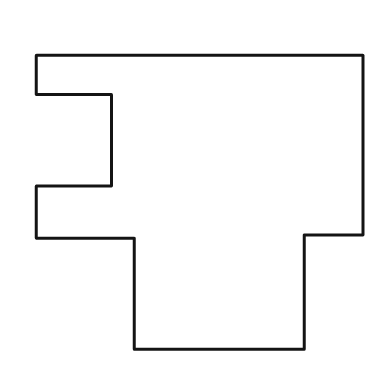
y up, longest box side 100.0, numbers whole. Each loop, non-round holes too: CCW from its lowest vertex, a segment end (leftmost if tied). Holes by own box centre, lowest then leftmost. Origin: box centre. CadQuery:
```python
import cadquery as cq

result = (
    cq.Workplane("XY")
    .moveTo(-20.0, -45.0)
    .lineTo(32.0, -45.0)
    .lineTo(32.0, -10.0)
    .lineTo(50.0, -10.0)
    .lineTo(50.0, 45.0)
    .lineTo(-50.0, 45.0)
    .lineTo(-50.0, 33.0)
    .lineTo(-27.0, 33.0)
    .lineTo(-27.0, 5.0)
    .lineTo(-50.0, 5.0)
    .lineTo(-50.0, -11.0)
    .lineTo(-20.0, -11.0)
    .close()
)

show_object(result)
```